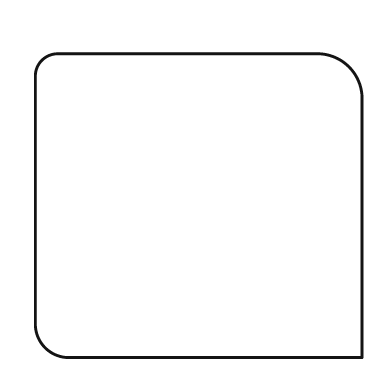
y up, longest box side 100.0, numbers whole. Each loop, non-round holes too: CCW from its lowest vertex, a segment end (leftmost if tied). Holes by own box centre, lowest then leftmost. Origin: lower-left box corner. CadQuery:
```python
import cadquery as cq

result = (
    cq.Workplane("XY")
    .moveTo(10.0, 0.0)
    .lineTo(100.0, 0.0)
    .lineTo(100.0, 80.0)
    .threePointArc((96.0, 89.0), (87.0, 93.0))
    .lineTo(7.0, 93.0)
    .threePointArc((2.0, 91.0), (0.0, 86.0))
    .lineTo(0.0, 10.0)
    .threePointArc((3.0, 3.0), (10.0, 0.0))
    .close()
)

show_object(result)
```